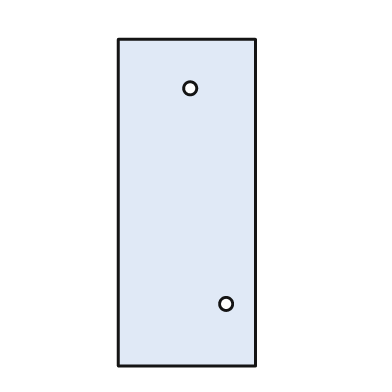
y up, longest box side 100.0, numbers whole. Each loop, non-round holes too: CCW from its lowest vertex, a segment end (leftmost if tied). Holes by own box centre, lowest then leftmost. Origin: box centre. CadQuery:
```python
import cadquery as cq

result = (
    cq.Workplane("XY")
    .moveTo(-21.0, -50.0)
    .lineTo(21.0, -50.0)
    .lineTo(21.0, 50.0)
    .lineTo(-21.0, 50.0)
    .close()
    .moveTo(12.0, -31.0)
    .circle(2.0)
    .moveTo(1.0, 35.0)
    .circle(2.0)
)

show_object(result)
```